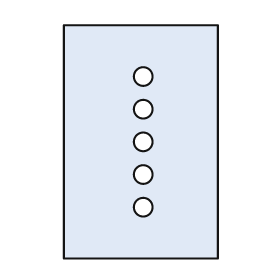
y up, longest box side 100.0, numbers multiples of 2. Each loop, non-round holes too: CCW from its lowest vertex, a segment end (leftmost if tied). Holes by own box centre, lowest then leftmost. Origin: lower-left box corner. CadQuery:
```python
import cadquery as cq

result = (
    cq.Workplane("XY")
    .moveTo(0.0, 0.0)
    .lineTo(66.0, 0.0)
    .lineTo(66.0, 100.0)
    .lineTo(0.0, 100.0)
    .close()
    .moveTo(34.0, 22.0)
    .circle(4.0)
    .moveTo(34.0, 36.0)
    .circle(4.0)
    .moveTo(34.0, 50.0)
    .circle(4.0)
    .moveTo(34.0, 64.0)
    .circle(4.0)
    .moveTo(34.0, 78.0)
    .circle(4.0)
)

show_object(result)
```